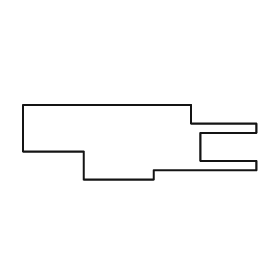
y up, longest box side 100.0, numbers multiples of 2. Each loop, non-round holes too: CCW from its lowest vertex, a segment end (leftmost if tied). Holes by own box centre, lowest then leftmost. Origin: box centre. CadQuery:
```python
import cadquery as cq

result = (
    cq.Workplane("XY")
    .moveTo(-24.0, -16.0)
    .lineTo(6.0, -16.0)
    .lineTo(6.0, -12.0)
    .lineTo(50.0, -12.0)
    .lineTo(50.0, -8.0)
    .lineTo(26.0, -8.0)
    .lineTo(26.0, 4.0)
    .lineTo(50.0, 4.0)
    .lineTo(50.0, 8.0)
    .lineTo(22.0, 8.0)
    .lineTo(22.0, 16.0)
    .lineTo(-50.0, 16.0)
    .lineTo(-50.0, -4.0)
    .lineTo(-24.0, -4.0)
    .close()
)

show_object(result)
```